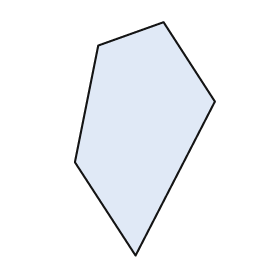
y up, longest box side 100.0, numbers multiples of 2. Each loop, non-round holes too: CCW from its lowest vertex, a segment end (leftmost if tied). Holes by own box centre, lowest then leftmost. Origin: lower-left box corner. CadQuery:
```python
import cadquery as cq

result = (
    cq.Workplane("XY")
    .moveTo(26.0, 0.0)
    .lineTo(60.0, 66.0)
    .lineTo(38.0, 100.0)
    .lineTo(10.0, 90.0)
    .lineTo(0.0, 40.0)
    .close()
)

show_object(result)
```